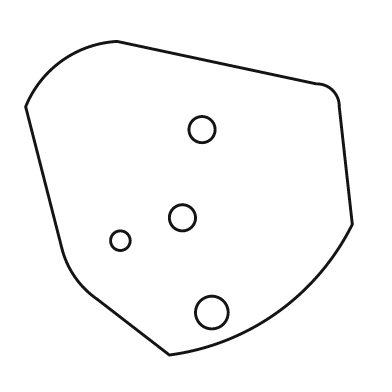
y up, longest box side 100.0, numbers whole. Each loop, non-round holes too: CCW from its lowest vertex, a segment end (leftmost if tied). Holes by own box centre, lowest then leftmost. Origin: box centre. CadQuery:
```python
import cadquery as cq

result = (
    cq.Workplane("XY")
    .moveTo(-6.0, -48.0)
    .threePointArc((27.0, -35.0), (50.0, -8.0))
    .lineTo(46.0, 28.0)
    .threePointArc((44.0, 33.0), (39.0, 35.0))
    .lineTo(-22.0, 48.0)
    .threePointArc((-39.0, 42.0), (-50.0, 28.0))
    .lineTo(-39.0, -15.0)
    .threePointArc((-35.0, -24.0), (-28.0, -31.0))
    .close()
    .moveTo(7.0, -35.0)
    .circle(5.0)
    .moveTo(-21.0, -13.0)
    .circle(3.0)
    .moveTo(-2.0, -6.0)
    .circle(4.0)
    .moveTo(4.0, 21.0)
    .circle(4.0)
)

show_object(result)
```